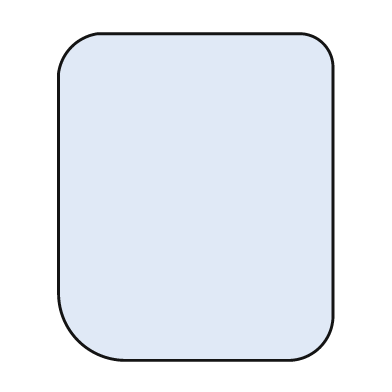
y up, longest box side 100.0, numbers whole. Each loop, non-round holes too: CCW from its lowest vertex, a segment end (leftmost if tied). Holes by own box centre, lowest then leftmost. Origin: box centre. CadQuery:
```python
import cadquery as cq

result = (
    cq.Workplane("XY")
    .moveTo(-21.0, -50.0)
    .lineTo(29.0, -50.0)
    .threePointArc((38.0, -46.0), (42.0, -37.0))
    .lineTo(42.0, 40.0)
    .threePointArc((39.0, 47.0), (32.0, 50.0))
    .lineTo(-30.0, 50.0)
    .threePointArc((-38.0, 46.0), (-42.0, 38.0))
    .lineTo(-42.0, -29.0)
    .threePointArc((-36.0, -44.0), (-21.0, -50.0))
    .close()
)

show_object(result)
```